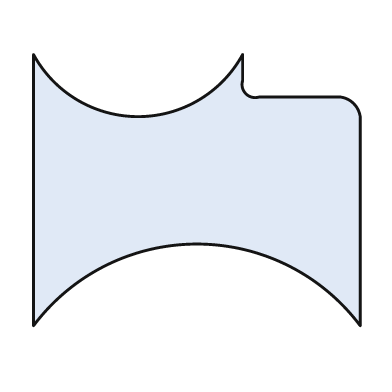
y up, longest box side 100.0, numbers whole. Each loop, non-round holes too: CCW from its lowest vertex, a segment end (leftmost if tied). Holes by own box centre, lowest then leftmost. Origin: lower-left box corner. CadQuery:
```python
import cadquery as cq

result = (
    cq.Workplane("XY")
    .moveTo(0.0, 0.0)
    .threePointArc((50.0, 25.0), (100.0, 0.0))
    .lineTo(100.0, 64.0)
    .threePointArc((98.0, 68.0), (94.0, 70.0))
    .lineTo(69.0, 70.0)
    .threePointArc((65.0, 71.0), (64.0, 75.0))
    .lineTo(64.0, 83.0)
    .threePointArc((32.0, 64.0), (0.0, 83.0))
    .close()
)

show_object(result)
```